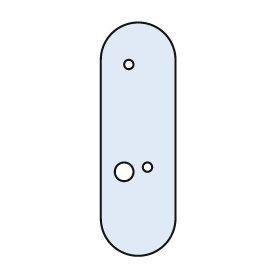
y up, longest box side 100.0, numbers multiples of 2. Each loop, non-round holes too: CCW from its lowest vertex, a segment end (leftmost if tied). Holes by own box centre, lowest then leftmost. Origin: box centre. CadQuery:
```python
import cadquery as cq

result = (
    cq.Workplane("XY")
    .moveTo(-16.0, -34.0)
    .threePointArc((0.0, -50.0), (16.0, -34.0))
    .lineTo(16.0, 34.0)
    .threePointArc((0.0, 50.0), (-16.0, 34.0))
    .close()
    .moveTo(-6.0, -14.0)
    .circle(4.0)
    .moveTo(4.0, -12.0)
    .circle(2.0)
    .moveTo(-4.0, 32.0)
    .circle(2.0)
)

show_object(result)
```